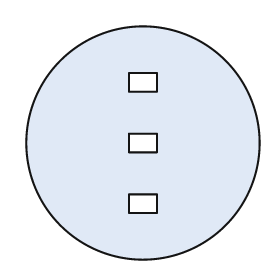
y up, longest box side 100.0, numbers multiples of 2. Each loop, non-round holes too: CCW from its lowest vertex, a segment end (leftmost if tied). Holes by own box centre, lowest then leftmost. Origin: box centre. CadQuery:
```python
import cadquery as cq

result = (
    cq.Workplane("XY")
    .moveTo(0.0, 0.0)
    .circle(50.0)
    .moveTo(-6.0, -30.0)
    .lineTo(6.0, -30.0)
    .lineTo(6.0, -22.0)
    .lineTo(-6.0, -22.0)
    .close()
    .moveTo(-6.0, -4.0)
    .lineTo(6.0, -4.0)
    .lineTo(6.0, 4.0)
    .lineTo(-6.0, 4.0)
    .close()
    .moveTo(-6.0, 22.0)
    .lineTo(6.0, 22.0)
    .lineTo(6.0, 30.0)
    .lineTo(-6.0, 30.0)
    .close()
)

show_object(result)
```